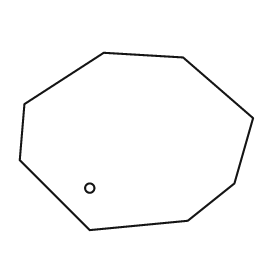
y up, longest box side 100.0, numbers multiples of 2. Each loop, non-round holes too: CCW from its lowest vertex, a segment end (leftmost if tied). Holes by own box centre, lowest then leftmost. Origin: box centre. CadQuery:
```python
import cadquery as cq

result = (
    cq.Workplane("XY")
    .moveTo(-20.0, -38.0)
    .lineTo(22.0, -34.0)
    .lineTo(42.0, -18.0)
    .lineTo(50.0, 10.0)
    .lineTo(20.0, 36.0)
    .lineTo(-14.0, 38.0)
    .lineTo(-48.0, 16.0)
    .lineTo(-50.0, -8.0)
    .close()
    .moveTo(-20.0, -20.0)
    .circle(2.0)
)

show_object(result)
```